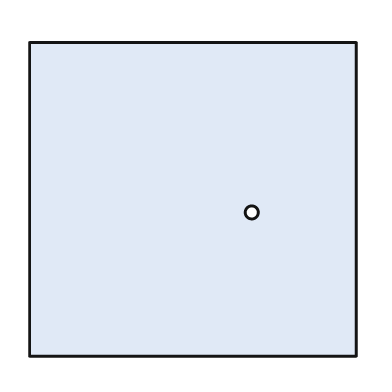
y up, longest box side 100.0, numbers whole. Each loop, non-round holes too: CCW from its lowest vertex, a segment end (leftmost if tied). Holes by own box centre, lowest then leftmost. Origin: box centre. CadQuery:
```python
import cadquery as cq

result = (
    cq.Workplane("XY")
    .moveTo(-50.0, -48.0)
    .lineTo(50.0, -48.0)
    .lineTo(50.0, 48.0)
    .lineTo(-50.0, 48.0)
    .close()
    .moveTo(18.0, -4.0)
    .circle(2.0)
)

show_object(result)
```